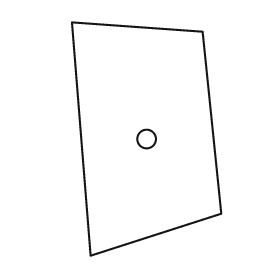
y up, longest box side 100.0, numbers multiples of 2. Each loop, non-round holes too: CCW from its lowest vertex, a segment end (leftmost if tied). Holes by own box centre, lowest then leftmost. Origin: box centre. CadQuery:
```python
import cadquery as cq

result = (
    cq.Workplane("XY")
    .moveTo(-24.0, -50.0)
    .lineTo(32.0, -32.0)
    .lineTo(24.0, 46.0)
    .lineTo(-32.0, 50.0)
    .close()
    .moveTo(0.0, 0.0)
    .circle(4.0)
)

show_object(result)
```